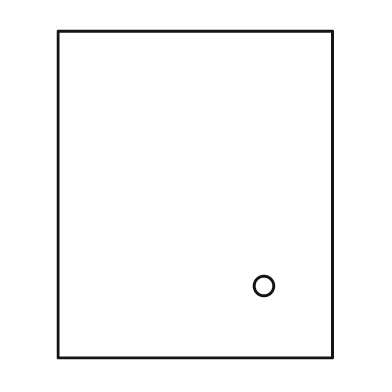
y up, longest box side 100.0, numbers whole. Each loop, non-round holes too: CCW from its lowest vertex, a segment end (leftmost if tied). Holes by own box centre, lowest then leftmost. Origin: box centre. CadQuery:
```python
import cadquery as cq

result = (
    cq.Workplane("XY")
    .moveTo(-42.0, -50.0)
    .lineTo(42.0, -50.0)
    .lineTo(42.0, 50.0)
    .lineTo(-42.0, 50.0)
    .close()
    .moveTo(21.0, -28.0)
    .circle(3.0)
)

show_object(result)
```